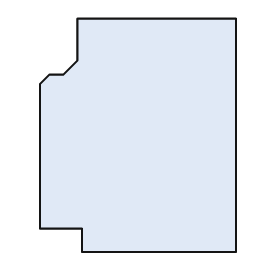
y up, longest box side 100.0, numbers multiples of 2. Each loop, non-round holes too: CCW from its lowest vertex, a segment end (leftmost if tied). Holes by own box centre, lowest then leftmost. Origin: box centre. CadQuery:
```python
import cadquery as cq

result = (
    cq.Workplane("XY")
    .moveTo(-24.0, -50.0)
    .lineTo(42.0, -50.0)
    .lineTo(42.0, 50.0)
    .lineTo(-26.0, 50.0)
    .lineTo(-26.0, 32.0)
    .lineTo(-32.0, 26.0)
    .lineTo(-38.0, 26.0)
    .lineTo(-42.0, 22.0)
    .lineTo(-42.0, -40.0)
    .lineTo(-24.0, -40.0)
    .close()
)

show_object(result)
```